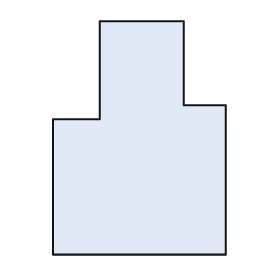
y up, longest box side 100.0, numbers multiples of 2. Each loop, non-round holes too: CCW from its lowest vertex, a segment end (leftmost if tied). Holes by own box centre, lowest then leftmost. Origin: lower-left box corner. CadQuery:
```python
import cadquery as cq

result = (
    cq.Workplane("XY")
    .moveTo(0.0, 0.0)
    .lineTo(74.0, 0.0)
    .lineTo(74.0, 64.0)
    .lineTo(56.0, 64.0)
    .lineTo(56.0, 100.0)
    .lineTo(20.0, 100.0)
    .lineTo(20.0, 58.0)
    .lineTo(0.0, 58.0)
    .close()
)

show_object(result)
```